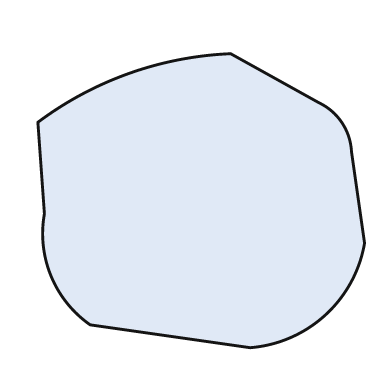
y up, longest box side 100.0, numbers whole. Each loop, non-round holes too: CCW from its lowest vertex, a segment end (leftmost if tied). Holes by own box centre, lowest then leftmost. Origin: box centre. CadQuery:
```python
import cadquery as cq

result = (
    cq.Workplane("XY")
    .moveTo(15.0, -45.0)
    .threePointArc((38.0, -35.0), (50.0, -13.0))
    .lineTo(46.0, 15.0)
    .threePointArc((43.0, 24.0), (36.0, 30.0))
    .lineTo(9.0, 45.0)
    .threePointArc((-22.0, 39.0), (-50.0, 24.0))
    .lineTo(-48.0, -4.0)
    .threePointArc((-46.0, -23.0), (-34.0, -38.0))
    .close()
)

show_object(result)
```